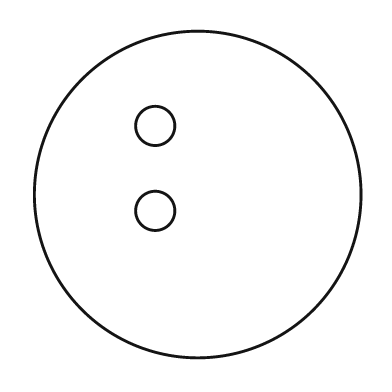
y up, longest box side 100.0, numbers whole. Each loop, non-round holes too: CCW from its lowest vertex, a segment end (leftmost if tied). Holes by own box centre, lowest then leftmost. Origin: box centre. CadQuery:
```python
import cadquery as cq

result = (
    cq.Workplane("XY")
    .moveTo(0.0, 0.0)
    .circle(50.0)
    .moveTo(-13.0, -5.0)
    .circle(6.0)
    .moveTo(-13.0, 21.0)
    .circle(6.0)
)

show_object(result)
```